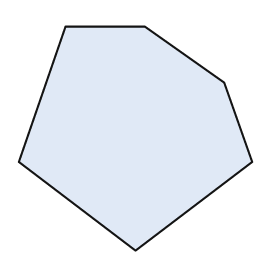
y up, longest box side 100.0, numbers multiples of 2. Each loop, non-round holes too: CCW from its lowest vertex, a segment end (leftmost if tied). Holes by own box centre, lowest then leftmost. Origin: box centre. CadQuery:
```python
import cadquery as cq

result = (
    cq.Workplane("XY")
    .moveTo(0.0, -48.0)
    .lineTo(50.0, -10.0)
    .lineTo(38.0, 24.0)
    .lineTo(4.0, 48.0)
    .lineTo(-30.0, 48.0)
    .lineTo(-50.0, -10.0)
    .close()
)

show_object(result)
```